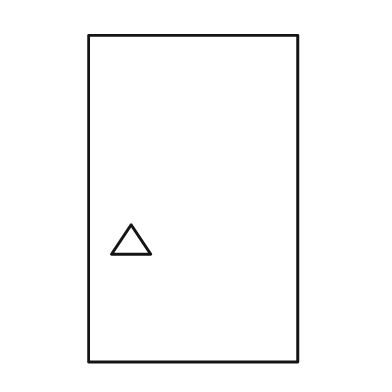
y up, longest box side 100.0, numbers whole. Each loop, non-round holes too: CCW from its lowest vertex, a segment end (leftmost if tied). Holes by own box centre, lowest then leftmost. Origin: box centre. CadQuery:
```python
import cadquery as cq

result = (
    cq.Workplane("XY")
    .moveTo(-32.0, -50.0)
    .lineTo(32.0, -50.0)
    .lineTo(32.0, 50.0)
    .lineTo(-32.0, 50.0)
    .close()
    .moveTo(-25.0, -17.0)
    .lineTo(-13.0, -17.0)
    .lineTo(-19.0, -8.0)
    .close()
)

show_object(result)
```